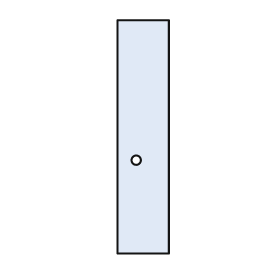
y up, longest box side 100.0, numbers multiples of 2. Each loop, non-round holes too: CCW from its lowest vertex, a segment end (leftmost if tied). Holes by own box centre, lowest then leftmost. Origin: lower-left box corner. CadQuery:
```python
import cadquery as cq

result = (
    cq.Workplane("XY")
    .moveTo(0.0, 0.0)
    .lineTo(22.0, 0.0)
    .lineTo(22.0, 100.0)
    .lineTo(0.0, 100.0)
    .close()
    .moveTo(8.0, 40.0)
    .circle(2.0)
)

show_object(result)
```